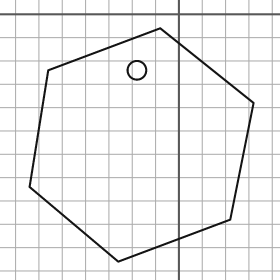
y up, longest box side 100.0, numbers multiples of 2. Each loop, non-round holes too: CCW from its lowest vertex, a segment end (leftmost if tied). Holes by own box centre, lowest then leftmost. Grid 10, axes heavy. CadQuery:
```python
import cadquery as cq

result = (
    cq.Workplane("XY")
    .moveTo(-26.0, -106.0)
    .lineTo(22.0, -88.0)
    .lineTo(32.0, -38.0)
    .lineTo(-8.0, -6.0)
    .lineTo(-56.0, -24.0)
    .lineTo(-64.0, -74.0)
    .close()
    .moveTo(-18.0, -24.0)
    .circle(4.0)
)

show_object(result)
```